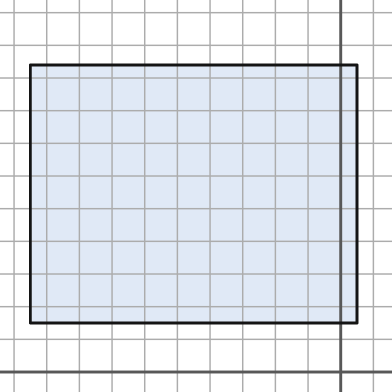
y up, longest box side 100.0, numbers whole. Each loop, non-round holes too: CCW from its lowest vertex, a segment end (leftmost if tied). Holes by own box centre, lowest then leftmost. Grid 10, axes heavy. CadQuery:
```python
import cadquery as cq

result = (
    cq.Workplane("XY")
    .moveTo(-95.0, 15.0)
    .lineTo(5.0, 15.0)
    .lineTo(5.0, 94.0)
    .lineTo(-95.0, 94.0)
    .close()
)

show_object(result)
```